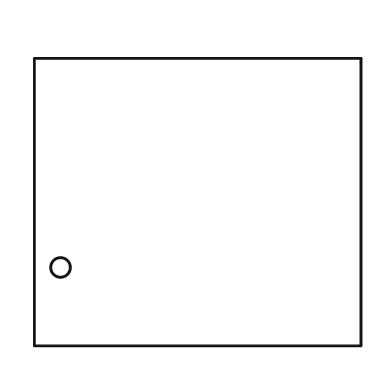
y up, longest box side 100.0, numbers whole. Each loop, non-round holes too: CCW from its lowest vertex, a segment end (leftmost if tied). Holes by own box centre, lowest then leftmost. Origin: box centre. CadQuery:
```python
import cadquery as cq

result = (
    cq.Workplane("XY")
    .moveTo(-50.0, -44.0)
    .lineTo(50.0, -44.0)
    .lineTo(50.0, 44.0)
    .lineTo(-50.0, 44.0)
    .close()
    .moveTo(-42.0, -20.0)
    .circle(3.0)
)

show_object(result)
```